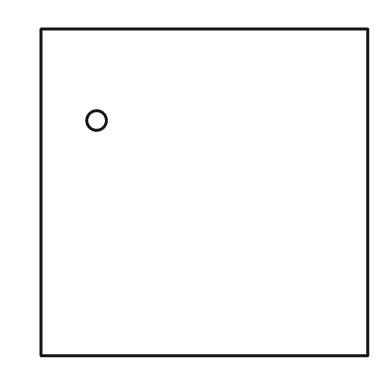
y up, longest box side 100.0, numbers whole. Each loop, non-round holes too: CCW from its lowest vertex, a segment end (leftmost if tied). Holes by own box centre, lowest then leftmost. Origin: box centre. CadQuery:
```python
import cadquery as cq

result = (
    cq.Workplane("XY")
    .moveTo(-50.0, -50.0)
    .lineTo(50.0, -50.0)
    .lineTo(50.0, 50.0)
    .lineTo(-50.0, 50.0)
    .close()
    .moveTo(-33.0, 22.0)
    .circle(3.0)
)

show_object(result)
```